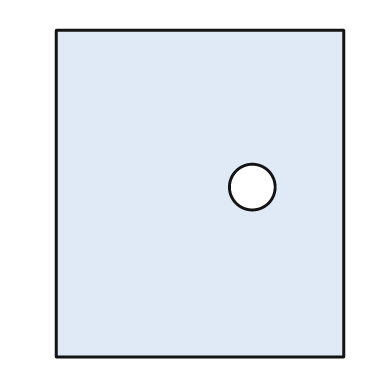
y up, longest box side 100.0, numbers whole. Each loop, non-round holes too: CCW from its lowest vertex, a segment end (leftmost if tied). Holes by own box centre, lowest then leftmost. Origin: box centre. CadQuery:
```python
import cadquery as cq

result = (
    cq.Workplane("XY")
    .moveTo(-44.0, -50.0)
    .lineTo(44.0, -50.0)
    .lineTo(44.0, 50.0)
    .lineTo(-44.0, 50.0)
    .close()
    .moveTo(16.0, 2.0)
    .circle(7.0)
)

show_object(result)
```